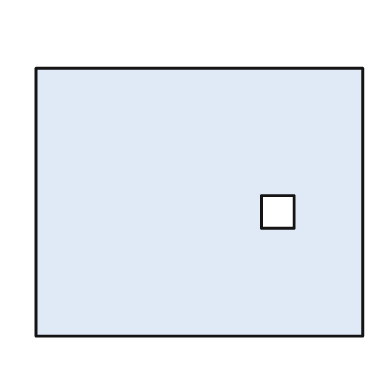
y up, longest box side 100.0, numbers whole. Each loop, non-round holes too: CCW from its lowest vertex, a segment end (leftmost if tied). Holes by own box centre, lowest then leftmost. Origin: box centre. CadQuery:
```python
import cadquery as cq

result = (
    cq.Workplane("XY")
    .moveTo(-50.0, -41.0)
    .lineTo(50.0, -41.0)
    .lineTo(50.0, 41.0)
    .lineTo(-50.0, 41.0)
    .close()
    .moveTo(19.0, -8.0)
    .lineTo(29.0, -8.0)
    .lineTo(29.0, 2.0)
    .lineTo(19.0, 2.0)
    .close()
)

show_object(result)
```